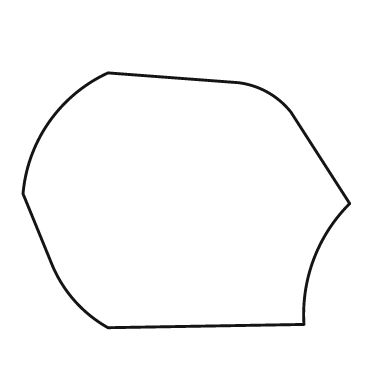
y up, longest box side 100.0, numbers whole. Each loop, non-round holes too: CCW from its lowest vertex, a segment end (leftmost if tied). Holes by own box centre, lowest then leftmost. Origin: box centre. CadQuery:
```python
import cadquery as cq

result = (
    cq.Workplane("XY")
    .moveTo(-24.0, -39.0)
    .lineTo(36.0, -38.0)
    .threePointArc((39.0, -18.0), (50.0, -1.0))
    .lineTo(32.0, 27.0)
    .threePointArc((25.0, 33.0), (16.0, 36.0))
    .lineTo(-24.0, 39.0)
    .threePointArc((-42.0, 24.0), (-50.0, 2.0))
    .lineTo(-41.0, -20.0)
    .threePointArc((-34.0, -31.0), (-24.0, -39.0))
    .close()
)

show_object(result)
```